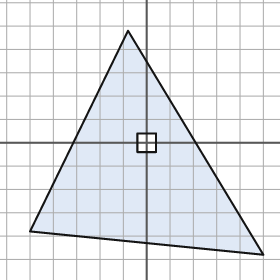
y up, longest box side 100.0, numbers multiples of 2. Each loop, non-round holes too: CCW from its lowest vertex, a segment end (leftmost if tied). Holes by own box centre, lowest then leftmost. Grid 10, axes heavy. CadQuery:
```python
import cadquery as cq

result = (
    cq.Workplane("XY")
    .moveTo(50.0, -48.0)
    .lineTo(-8.0, 48.0)
    .lineTo(-50.0, -38.0)
    .close()
    .moveTo(-4.0, -4.0)
    .lineTo(4.0, -4.0)
    .lineTo(4.0, 4.0)
    .lineTo(-4.0, 4.0)
    .close()
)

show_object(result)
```